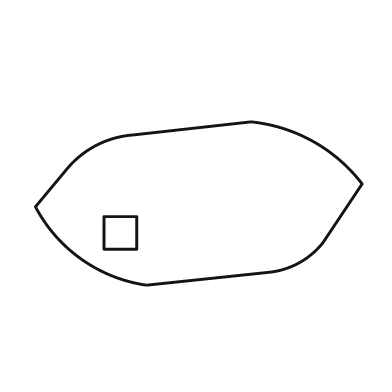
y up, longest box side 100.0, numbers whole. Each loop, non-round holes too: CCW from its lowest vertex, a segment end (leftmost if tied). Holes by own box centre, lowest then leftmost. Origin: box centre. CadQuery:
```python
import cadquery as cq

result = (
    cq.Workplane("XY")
    .moveTo(-16.0, -25.0)
    .lineTo(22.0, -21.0)
    .threePointArc((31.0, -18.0), (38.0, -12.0))
    .lineTo(50.0, 6.0)
    .threePointArc((35.0, 19.0), (16.0, 25.0))
    .lineTo(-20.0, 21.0)
    .threePointArc((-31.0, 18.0), (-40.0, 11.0))
    .lineTo(-50.0, -1.0)
    .threePointArc((-36.0, -17.0), (-16.0, -25.0))
    .close()
    .moveTo(-29.0, -14.0)
    .lineTo(-19.0, -14.0)
    .lineTo(-19.0, -4.0)
    .lineTo(-29.0, -4.0)
    .close()
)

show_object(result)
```